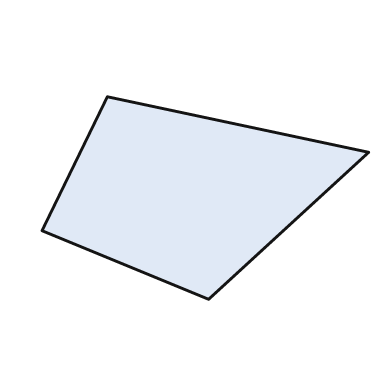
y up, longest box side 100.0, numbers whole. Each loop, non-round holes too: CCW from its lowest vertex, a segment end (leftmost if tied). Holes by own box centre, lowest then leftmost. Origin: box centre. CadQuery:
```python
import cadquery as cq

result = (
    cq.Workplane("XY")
    .moveTo(1.0, -31.0)
    .lineTo(50.0, 14.0)
    .lineTo(-30.0, 31.0)
    .lineTo(-50.0, -10.0)
    .close()
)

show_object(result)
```